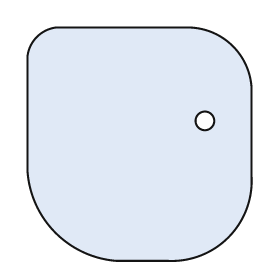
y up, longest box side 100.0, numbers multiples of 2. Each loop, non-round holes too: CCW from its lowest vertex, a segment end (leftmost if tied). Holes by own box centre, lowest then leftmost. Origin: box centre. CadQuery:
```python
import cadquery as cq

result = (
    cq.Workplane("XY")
    .moveTo(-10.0, -50.0)
    .lineTo(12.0, -50.0)
    .threePointArc((38.0, -40.0), (48.0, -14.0))
    .lineTo(48.0, 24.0)
    .threePointArc((40.0, 42.0), (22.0, 50.0))
    .lineTo(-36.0, 50.0)
    .threePointArc((-44.0, 46.0), (-48.0, 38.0))
    .lineTo(-48.0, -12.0)
    .threePointArc((-36.0, -38.0), (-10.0, -50.0))
    .close()
    .moveTo(28.0, 10.0)
    .circle(4.0)
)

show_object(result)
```